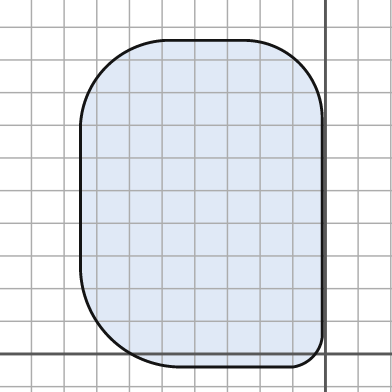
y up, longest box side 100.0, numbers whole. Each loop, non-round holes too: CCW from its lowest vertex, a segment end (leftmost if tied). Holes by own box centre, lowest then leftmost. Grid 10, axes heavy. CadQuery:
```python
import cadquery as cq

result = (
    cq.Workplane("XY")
    .moveTo(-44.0, -4.0)
    .lineTo(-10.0, -4.0)
    .threePointArc((-4.0, -1.0), (-1.0, 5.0))
    .lineTo(-1.0, 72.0)
    .threePointArc((-8.0, 89.0), (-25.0, 96.0))
    .lineTo(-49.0, 96.0)
    .threePointArc((-67.0, 88.0), (-75.0, 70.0))
    .lineTo(-75.0, 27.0)
    .threePointArc((-66.0, 5.0), (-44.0, -4.0))
    .close()
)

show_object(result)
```